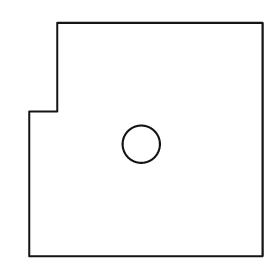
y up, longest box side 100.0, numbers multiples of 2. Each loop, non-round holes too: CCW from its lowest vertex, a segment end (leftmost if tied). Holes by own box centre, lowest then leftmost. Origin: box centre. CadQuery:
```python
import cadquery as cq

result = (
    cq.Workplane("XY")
    .moveTo(-50.0, -50.0)
    .lineTo(50.0, -50.0)
    .lineTo(50.0, 50.0)
    .lineTo(-38.0, 50.0)
    .lineTo(-38.0, 12.0)
    .lineTo(-50.0, 12.0)
    .close()
    .moveTo(-2.0, -2.0)
    .circle(8.0)
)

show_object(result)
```